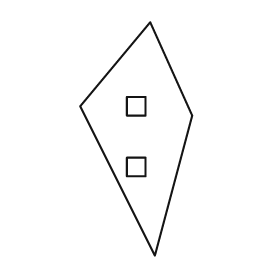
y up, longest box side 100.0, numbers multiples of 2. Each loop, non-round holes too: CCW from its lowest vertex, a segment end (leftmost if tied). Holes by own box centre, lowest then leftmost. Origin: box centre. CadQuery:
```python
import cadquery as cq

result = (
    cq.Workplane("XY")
    .moveTo(8.0, -50.0)
    .lineTo(24.0, 10.0)
    .lineTo(6.0, 50.0)
    .lineTo(-24.0, 14.0)
    .close()
    .moveTo(-4.0, -16.0)
    .lineTo(4.0, -16.0)
    .lineTo(4.0, -8.0)
    .lineTo(-4.0, -8.0)
    .close()
    .moveTo(-4.0, 10.0)
    .lineTo(4.0, 10.0)
    .lineTo(4.0, 18.0)
    .lineTo(-4.0, 18.0)
    .close()
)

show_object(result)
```